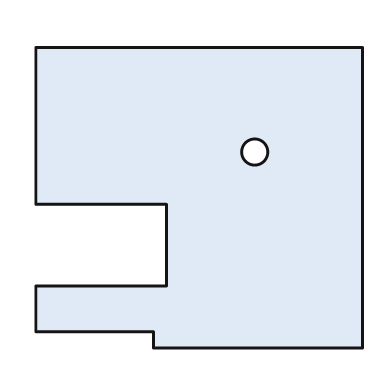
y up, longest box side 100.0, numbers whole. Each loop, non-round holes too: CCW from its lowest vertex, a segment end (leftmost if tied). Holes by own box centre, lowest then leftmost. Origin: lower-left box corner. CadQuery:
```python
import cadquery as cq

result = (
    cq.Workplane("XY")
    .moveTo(36.0, 0.0)
    .lineTo(100.0, 0.0)
    .lineTo(100.0, 92.0)
    .lineTo(0.0, 92.0)
    .lineTo(0.0, 44.0)
    .lineTo(40.0, 44.0)
    .lineTo(40.0, 19.0)
    .lineTo(0.0, 19.0)
    .lineTo(0.0, 5.0)
    .lineTo(36.0, 5.0)
    .close()
    .moveTo(67.0, 60.0)
    .circle(4.0)
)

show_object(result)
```